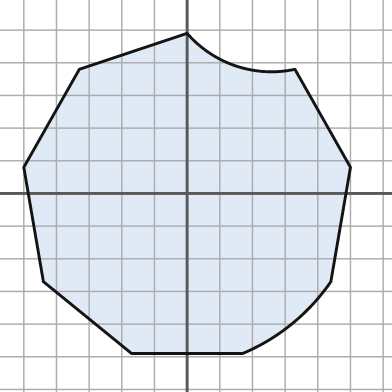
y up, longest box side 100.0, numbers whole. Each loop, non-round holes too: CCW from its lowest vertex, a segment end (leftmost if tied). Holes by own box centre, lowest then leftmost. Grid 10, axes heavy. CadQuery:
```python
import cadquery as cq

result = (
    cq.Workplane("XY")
    .moveTo(-17.0, -49.0)
    .lineTo(17.0, -49.0)
    .threePointArc((32.0, -40.0), (44.0, -27.0))
    .lineTo(50.0, 8.0)
    .lineTo(33.0, 38.0)
    .threePointArc((15.0, 39.0), (0.0, 49.0))
    .lineTo(-33.0, 38.0)
    .lineTo(-50.0, 8.0)
    .lineTo(-44.0, -27.0)
    .close()
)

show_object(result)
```